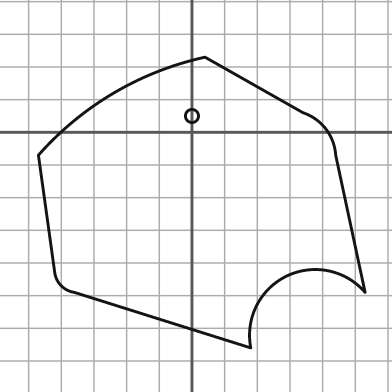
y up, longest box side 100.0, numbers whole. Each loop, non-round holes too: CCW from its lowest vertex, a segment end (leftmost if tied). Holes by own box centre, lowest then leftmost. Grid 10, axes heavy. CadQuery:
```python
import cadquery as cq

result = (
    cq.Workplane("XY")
    .moveTo(18.0, -66.0)
    .threePointArc((29.0, -44.0), (53.0, -49.0))
    .lineTo(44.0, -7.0)
    .threePointArc((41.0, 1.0), (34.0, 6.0))
    .lineTo(4.0, 23.0)
    .threePointArc((-24.0, 12.0), (-47.0, -7.0))
    .lineTo(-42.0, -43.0)
    .threePointArc((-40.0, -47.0), (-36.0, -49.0))
    .close()
    .moveTo(0.0, 5.0)
    .circle(2.0)
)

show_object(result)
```